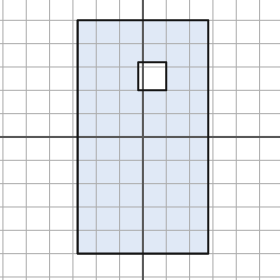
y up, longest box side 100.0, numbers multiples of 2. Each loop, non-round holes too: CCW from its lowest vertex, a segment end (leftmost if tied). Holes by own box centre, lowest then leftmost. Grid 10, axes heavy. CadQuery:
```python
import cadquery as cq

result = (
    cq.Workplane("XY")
    .moveTo(-28.0, -50.0)
    .lineTo(28.0, -50.0)
    .lineTo(28.0, 50.0)
    .lineTo(-28.0, 50.0)
    .close()
    .moveTo(-2.0, 20.0)
    .lineTo(10.0, 20.0)
    .lineTo(10.0, 32.0)
    .lineTo(-2.0, 32.0)
    .close()
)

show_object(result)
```